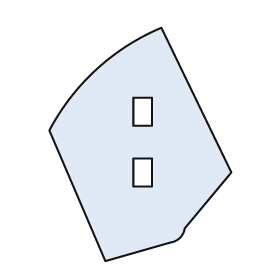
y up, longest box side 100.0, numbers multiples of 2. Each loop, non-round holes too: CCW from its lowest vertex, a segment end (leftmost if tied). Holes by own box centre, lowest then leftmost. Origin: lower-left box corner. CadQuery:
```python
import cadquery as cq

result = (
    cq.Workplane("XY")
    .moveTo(24.0, 0.0)
    .lineTo(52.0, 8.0)
    .threePointArc((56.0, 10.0), (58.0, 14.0))
    .lineTo(78.0, 38.0)
    .lineTo(48.0, 100.0)
    .threePointArc((20.0, 82.0), (0.0, 56.0))
    .close()
    .moveTo(36.0, 32.0)
    .lineTo(44.0, 32.0)
    .lineTo(44.0, 44.0)
    .lineTo(36.0, 44.0)
    .close()
    .moveTo(36.0, 58.0)
    .lineTo(44.0, 58.0)
    .lineTo(44.0, 70.0)
    .lineTo(36.0, 70.0)
    .close()
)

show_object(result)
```